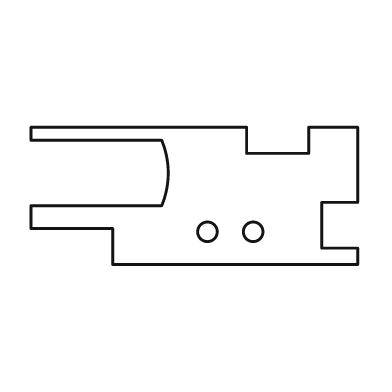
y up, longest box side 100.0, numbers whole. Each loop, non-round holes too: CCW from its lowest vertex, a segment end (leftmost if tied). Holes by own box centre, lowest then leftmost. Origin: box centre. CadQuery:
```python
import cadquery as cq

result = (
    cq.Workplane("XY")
    .moveTo(-25.0, -21.0)
    .lineTo(50.0, -21.0)
    .lineTo(50.0, -16.0)
    .lineTo(39.0, -16.0)
    .lineTo(39.0, -2.0)
    .lineTo(50.0, -2.0)
    .lineTo(50.0, 21.0)
    .lineTo(35.0, 21.0)
    .lineTo(35.0, 13.0)
    .lineTo(16.0, 13.0)
    .lineTo(16.0, 21.0)
    .lineTo(-50.0, 21.0)
    .lineTo(-50.0, 17.0)
    .lineTo(-10.0, 17.0)
    .threePointArc((-8.0, 7.0), (-10.0, -3.0))
    .lineTo(-50.0, -3.0)
    .lineTo(-50.0, -10.0)
    .lineTo(-25.0, -10.0)
    .close()
    .moveTo(4.0, -11.0)
    .circle(3.0)
    .moveTo(18.0, -11.0)
    .circle(3.0)
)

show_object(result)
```